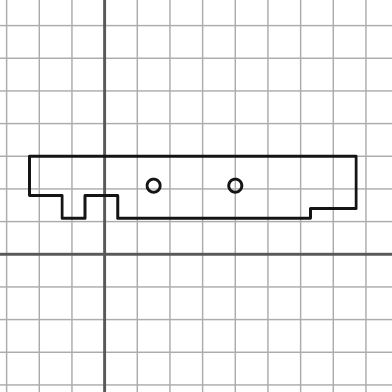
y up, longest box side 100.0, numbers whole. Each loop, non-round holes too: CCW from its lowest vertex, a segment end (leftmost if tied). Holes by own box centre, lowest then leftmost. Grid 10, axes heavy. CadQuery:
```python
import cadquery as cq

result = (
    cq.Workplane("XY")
    .moveTo(-13.0, 11.0)
    .lineTo(-6.0, 11.0)
    .lineTo(-6.0, 18.0)
    .lineTo(4.0, 18.0)
    .lineTo(4.0, 11.0)
    .lineTo(63.0, 11.0)
    .lineTo(63.0, 14.0)
    .lineTo(77.0, 14.0)
    .lineTo(77.0, 30.0)
    .lineTo(-23.0, 30.0)
    .lineTo(-23.0, 18.0)
    .lineTo(-13.0, 18.0)
    .close()
    .moveTo(15.0, 21.0)
    .circle(2.0)
    .moveTo(40.0, 21.0)
    .circle(2.0)
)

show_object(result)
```